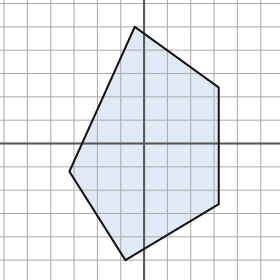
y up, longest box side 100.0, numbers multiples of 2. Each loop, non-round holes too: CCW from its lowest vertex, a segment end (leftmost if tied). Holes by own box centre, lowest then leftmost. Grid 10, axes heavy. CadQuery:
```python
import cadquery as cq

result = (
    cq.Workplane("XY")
    .moveTo(-8.0, -50.0)
    .lineTo(32.0, -26.0)
    .lineTo(32.0, 24.0)
    .lineTo(-4.0, 50.0)
    .lineTo(-32.0, -12.0)
    .close()
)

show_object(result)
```